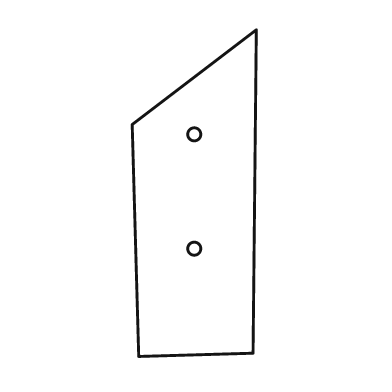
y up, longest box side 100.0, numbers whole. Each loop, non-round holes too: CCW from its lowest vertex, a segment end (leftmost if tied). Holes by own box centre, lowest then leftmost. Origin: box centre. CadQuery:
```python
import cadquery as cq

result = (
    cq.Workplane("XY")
    .moveTo(-17.0, -50.0)
    .lineTo(18.0, -49.0)
    .lineTo(19.0, 50.0)
    .lineTo(-19.0, 21.0)
    .close()
    .moveTo(0.0, -17.0)
    .circle(2.0)
    .moveTo(0.0, 18.0)
    .circle(2.0)
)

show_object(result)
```